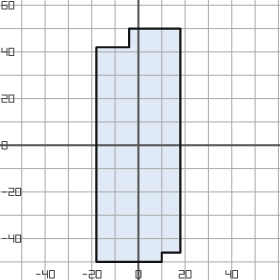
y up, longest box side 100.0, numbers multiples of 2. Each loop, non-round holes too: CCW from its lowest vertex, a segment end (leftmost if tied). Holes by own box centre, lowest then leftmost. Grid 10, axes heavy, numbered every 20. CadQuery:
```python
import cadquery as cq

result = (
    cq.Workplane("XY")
    .moveTo(-18.0, -50.0)
    .lineTo(10.0, -50.0)
    .lineTo(10.0, -46.0)
    .lineTo(18.0, -46.0)
    .lineTo(18.0, 50.0)
    .lineTo(-4.0, 50.0)
    .lineTo(-4.0, 42.0)
    .lineTo(-18.0, 42.0)
    .close()
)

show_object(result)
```